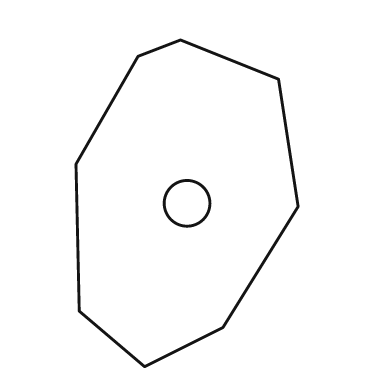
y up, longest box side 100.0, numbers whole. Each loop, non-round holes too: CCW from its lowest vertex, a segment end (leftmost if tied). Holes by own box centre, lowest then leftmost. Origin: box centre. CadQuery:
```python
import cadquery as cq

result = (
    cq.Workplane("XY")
    .moveTo(-13.0, -50.0)
    .lineTo(11.0, -38.0)
    .lineTo(34.0, -1.0)
    .lineTo(28.0, 38.0)
    .lineTo(-2.0, 50.0)
    .lineTo(-15.0, 45.0)
    .lineTo(-34.0, 12.0)
    .lineTo(-33.0, -33.0)
    .close()
    .moveTo(0.0, 0.0)
    .circle(7.0)
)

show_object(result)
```